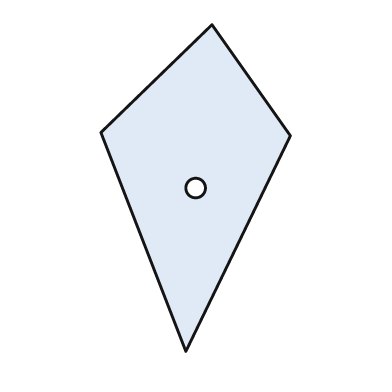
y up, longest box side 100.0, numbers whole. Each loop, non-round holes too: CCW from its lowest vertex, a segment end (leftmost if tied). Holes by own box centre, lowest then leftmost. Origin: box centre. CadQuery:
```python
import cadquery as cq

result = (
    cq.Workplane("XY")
    .moveTo(-3.0, -50.0)
    .lineTo(29.0, 16.0)
    .lineTo(5.0, 50.0)
    .lineTo(-29.0, 17.0)
    .close()
    .moveTo(0.0, 0.0)
    .circle(3.0)
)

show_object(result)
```